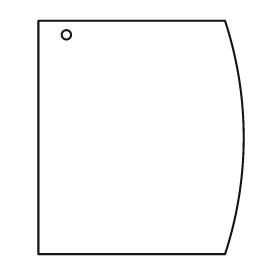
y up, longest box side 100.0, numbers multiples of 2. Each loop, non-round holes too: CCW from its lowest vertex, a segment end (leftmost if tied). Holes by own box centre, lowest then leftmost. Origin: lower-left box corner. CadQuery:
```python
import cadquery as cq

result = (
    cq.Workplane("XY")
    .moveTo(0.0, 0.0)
    .lineTo(80.0, 0.0)
    .threePointArc((88.0, 50.0), (80.0, 100.0))
    .lineTo(0.0, 100.0)
    .close()
    .moveTo(12.0, 94.0)
    .circle(2.0)
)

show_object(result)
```